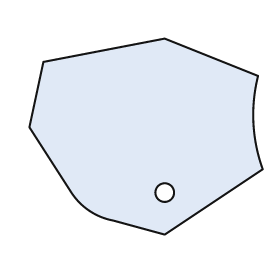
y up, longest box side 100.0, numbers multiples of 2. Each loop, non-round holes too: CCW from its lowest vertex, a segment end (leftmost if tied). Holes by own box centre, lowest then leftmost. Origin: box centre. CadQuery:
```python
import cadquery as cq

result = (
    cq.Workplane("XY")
    .moveTo(8.0, -42.0)
    .lineTo(50.0, -14.0)
    .threePointArc((46.0, 6.0), (48.0, 26.0))
    .lineTo(8.0, 42.0)
    .lineTo(-44.0, 32.0)
    .lineTo(-50.0, 4.0)
    .lineTo(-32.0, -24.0)
    .threePointArc((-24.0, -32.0), (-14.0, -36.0))
    .close()
    .moveTo(8.0, -24.0)
    .circle(4.0)
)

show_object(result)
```